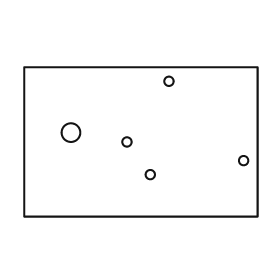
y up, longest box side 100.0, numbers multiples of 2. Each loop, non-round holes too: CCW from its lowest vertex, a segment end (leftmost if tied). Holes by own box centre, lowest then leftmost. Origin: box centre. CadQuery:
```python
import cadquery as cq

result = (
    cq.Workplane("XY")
    .moveTo(-50.0, -32.0)
    .lineTo(50.0, -32.0)
    .lineTo(50.0, 32.0)
    .lineTo(-50.0, 32.0)
    .close()
    .moveTo(4.0, -14.0)
    .circle(2.0)
    .moveTo(44.0, -8.0)
    .circle(2.0)
    .moveTo(-6.0, 0.0)
    .circle(2.0)
    .moveTo(-30.0, 4.0)
    .circle(4.0)
    .moveTo(12.0, 26.0)
    .circle(2.0)
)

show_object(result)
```